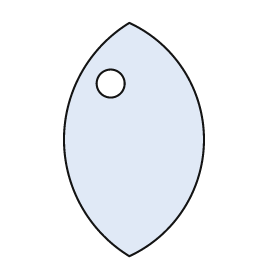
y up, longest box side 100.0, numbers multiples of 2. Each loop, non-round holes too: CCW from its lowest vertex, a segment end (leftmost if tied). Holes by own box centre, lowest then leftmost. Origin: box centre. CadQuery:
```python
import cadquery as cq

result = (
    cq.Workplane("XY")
    .moveTo(-2.0, -50.0)
    .threePointArc((30.0, 0.0), (-2.0, 50.0))
    .threePointArc((-30.0, 0.0), (-2.0, -50.0))
    .close()
    .moveTo(-10.0, 24.0)
    .circle(6.0)
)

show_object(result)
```